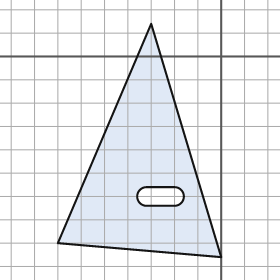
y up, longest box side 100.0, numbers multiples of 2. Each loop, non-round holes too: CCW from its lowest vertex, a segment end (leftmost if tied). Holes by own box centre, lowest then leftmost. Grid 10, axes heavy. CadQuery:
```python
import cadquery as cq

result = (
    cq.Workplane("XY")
    .moveTo(0.0, -86.0)
    .lineTo(-30.0, 14.0)
    .lineTo(-70.0, -80.0)
    .close()
    .moveTo(-32.0, -64.0)
    .lineTo(-20.0, -64.0)
    .threePointArc((-16.0, -60.0), (-20.0, -56.0))
    .lineTo(-32.0, -56.0)
    .threePointArc((-36.0, -60.0), (-32.0, -64.0))
    .close()
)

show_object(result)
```